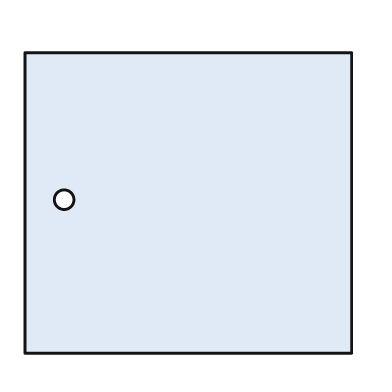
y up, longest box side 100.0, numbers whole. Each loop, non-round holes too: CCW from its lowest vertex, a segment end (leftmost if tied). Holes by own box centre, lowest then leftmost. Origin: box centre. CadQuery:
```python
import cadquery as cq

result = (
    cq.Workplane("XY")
    .moveTo(-50.0, -46.0)
    .lineTo(50.0, -46.0)
    .lineTo(50.0, 46.0)
    .lineTo(-50.0, 46.0)
    .close()
    .moveTo(-38.0, 1.0)
    .circle(3.0)
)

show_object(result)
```